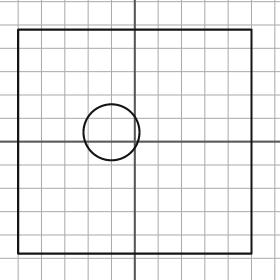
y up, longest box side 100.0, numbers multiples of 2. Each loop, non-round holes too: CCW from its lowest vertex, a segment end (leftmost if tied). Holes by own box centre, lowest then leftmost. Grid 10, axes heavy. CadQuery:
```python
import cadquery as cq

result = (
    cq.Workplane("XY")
    .moveTo(-50.0, -48.0)
    .lineTo(50.0, -48.0)
    .lineTo(50.0, 48.0)
    .lineTo(-50.0, 48.0)
    .close()
    .moveTo(-10.0, 4.0)
    .circle(12.0)
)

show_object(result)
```